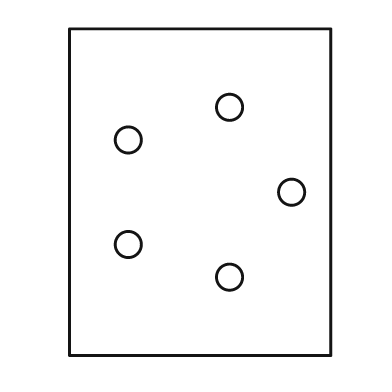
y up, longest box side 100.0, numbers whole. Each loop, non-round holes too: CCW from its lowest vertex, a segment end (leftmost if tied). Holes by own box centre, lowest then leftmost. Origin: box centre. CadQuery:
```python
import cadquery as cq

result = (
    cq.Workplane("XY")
    .moveTo(-40.0, -50.0)
    .lineTo(40.0, -50.0)
    .lineTo(40.0, 50.0)
    .lineTo(-40.0, 50.0)
    .close()
    .moveTo(9.0, -26.0)
    .circle(4.0)
    .moveTo(-22.0, -16.0)
    .circle(4.0)
    .moveTo(28.0, 0.0)
    .circle(4.0)
    .moveTo(-22.0, 16.0)
    .circle(4.0)
    .moveTo(9.0, 26.0)
    .circle(4.0)
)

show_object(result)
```